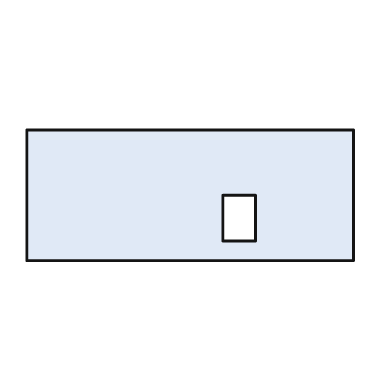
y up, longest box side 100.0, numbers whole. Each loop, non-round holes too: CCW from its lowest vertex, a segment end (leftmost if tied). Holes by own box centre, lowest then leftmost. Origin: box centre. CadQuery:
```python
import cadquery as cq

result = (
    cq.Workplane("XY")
    .moveTo(-50.0, -20.0)
    .lineTo(50.0, -20.0)
    .lineTo(50.0, 20.0)
    .lineTo(-50.0, 20.0)
    .close()
    .moveTo(10.0, -14.0)
    .lineTo(20.0, -14.0)
    .lineTo(20.0, 0.0)
    .lineTo(10.0, 0.0)
    .close()
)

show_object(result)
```